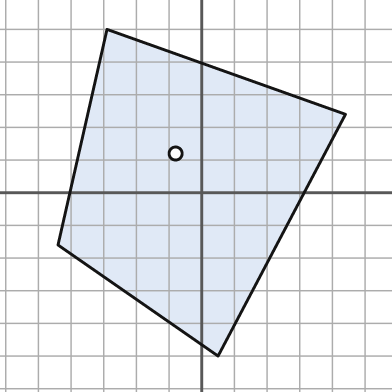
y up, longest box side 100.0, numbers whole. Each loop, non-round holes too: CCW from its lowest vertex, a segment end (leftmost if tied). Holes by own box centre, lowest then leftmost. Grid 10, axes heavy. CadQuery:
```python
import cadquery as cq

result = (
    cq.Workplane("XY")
    .moveTo(5.0, -50.0)
    .lineTo(44.0, 24.0)
    .lineTo(-29.0, 50.0)
    .lineTo(-44.0, -16.0)
    .close()
    .moveTo(-8.0, 12.0)
    .circle(2.0)
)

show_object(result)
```